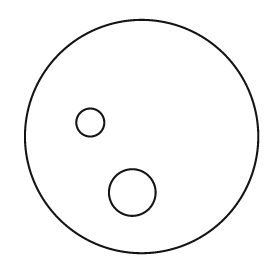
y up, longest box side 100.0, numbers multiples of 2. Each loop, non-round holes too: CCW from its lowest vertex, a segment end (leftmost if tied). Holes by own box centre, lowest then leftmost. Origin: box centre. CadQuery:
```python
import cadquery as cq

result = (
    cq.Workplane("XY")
    .moveTo(0.0, 0.0)
    .circle(50.0)
    .moveTo(-4.0, -24.0)
    .circle(10.0)
    .moveTo(-22.0, 6.0)
    .circle(6.0)
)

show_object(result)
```